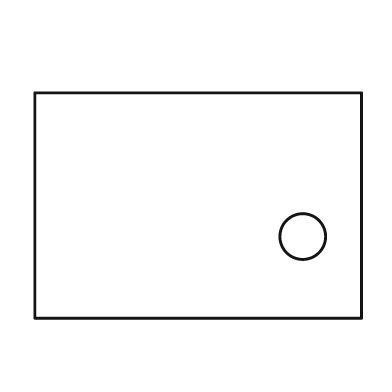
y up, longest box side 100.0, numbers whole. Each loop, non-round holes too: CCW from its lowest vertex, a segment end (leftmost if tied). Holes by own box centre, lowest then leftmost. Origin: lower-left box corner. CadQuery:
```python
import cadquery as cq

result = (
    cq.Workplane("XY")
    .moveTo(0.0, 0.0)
    .lineTo(100.0, 0.0)
    .lineTo(100.0, 69.0)
    .lineTo(0.0, 69.0)
    .close()
    .moveTo(82.0, 25.0)
    .circle(7.0)
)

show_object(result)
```